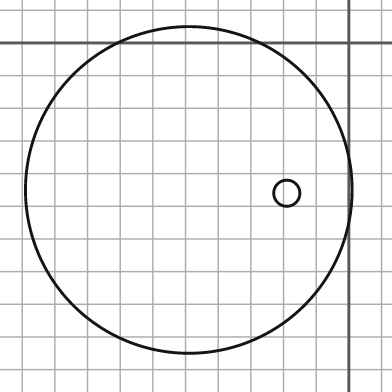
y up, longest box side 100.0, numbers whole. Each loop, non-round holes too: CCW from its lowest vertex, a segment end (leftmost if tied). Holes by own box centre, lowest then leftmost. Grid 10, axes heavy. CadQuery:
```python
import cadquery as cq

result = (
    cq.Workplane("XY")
    .moveTo(-49.0, -45.0)
    .circle(50.0)
    .moveTo(-19.0, -46.0)
    .circle(4.0)
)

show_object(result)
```